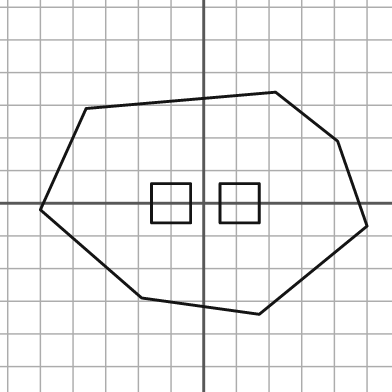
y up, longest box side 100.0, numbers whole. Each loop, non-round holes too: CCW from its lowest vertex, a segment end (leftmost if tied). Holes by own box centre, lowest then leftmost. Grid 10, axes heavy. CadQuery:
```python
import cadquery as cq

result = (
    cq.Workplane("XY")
    .moveTo(17.0, -34.0)
    .lineTo(50.0, -7.0)
    .lineTo(41.0, 19.0)
    .lineTo(22.0, 34.0)
    .lineTo(-36.0, 29.0)
    .lineTo(-50.0, -2.0)
    .lineTo(-19.0, -29.0)
    .close()
    .moveTo(-16.0, -6.0)
    .lineTo(-4.0, -6.0)
    .lineTo(-4.0, 6.0)
    .lineTo(-16.0, 6.0)
    .close()
    .moveTo(5.0, -6.0)
    .lineTo(17.0, -6.0)
    .lineTo(17.0, 6.0)
    .lineTo(5.0, 6.0)
    .close()
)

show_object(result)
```